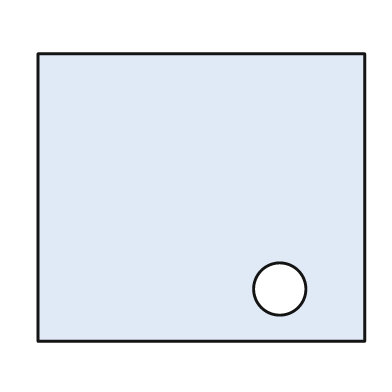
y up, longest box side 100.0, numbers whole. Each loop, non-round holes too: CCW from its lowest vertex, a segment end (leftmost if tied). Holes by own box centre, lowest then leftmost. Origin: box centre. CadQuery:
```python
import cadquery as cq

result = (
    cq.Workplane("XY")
    .moveTo(-50.0, -44.0)
    .lineTo(50.0, -44.0)
    .lineTo(50.0, 44.0)
    .lineTo(-50.0, 44.0)
    .close()
    .moveTo(24.0, -28.0)
    .circle(8.0)
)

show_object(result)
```